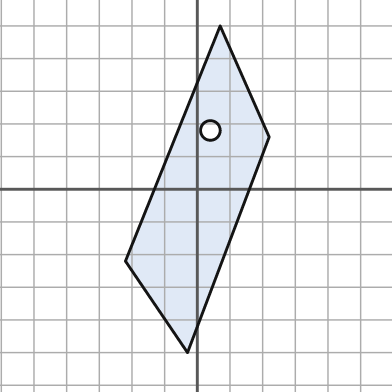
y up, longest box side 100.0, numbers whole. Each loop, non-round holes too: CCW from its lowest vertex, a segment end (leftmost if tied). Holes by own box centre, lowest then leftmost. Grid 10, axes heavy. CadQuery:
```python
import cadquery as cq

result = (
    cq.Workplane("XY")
    .moveTo(-3.0, -50.0)
    .lineTo(22.0, 16.0)
    .lineTo(7.0, 50.0)
    .lineTo(-22.0, -22.0)
    .close()
    .moveTo(4.0, 18.0)
    .circle(3.0)
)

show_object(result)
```